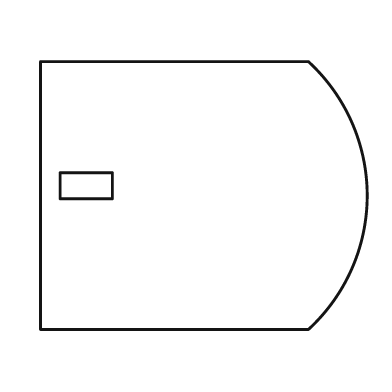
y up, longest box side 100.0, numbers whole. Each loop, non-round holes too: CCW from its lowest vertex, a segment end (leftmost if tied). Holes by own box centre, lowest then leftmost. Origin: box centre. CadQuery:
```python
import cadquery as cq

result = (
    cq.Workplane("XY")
    .moveTo(-50.0, -41.0)
    .lineTo(32.0, -41.0)
    .threePointArc((50.0, 0.0), (32.0, 41.0))
    .lineTo(-50.0, 41.0)
    .close()
    .moveTo(-44.0, -1.0)
    .lineTo(-28.0, -1.0)
    .lineTo(-28.0, 7.0)
    .lineTo(-44.0, 7.0)
    .close()
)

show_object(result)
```